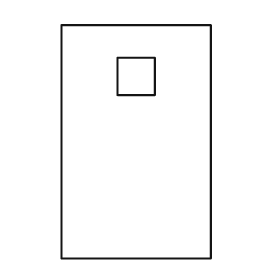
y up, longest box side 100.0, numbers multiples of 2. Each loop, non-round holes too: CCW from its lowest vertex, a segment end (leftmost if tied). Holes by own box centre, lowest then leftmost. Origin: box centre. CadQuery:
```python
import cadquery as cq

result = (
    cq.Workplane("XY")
    .moveTo(-32.0, -50.0)
    .lineTo(32.0, -50.0)
    .lineTo(32.0, 50.0)
    .lineTo(-32.0, 50.0)
    .close()
    .moveTo(-8.0, 20.0)
    .lineTo(8.0, 20.0)
    .lineTo(8.0, 36.0)
    .lineTo(-8.0, 36.0)
    .close()
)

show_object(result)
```